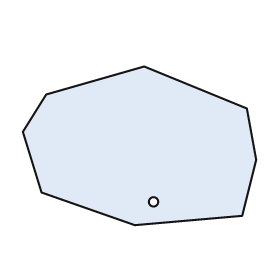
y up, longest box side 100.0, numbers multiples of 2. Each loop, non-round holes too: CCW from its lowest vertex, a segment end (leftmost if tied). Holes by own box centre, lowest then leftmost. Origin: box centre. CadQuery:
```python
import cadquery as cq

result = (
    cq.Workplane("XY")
    .moveTo(-2.0, -34.0)
    .lineTo(44.0, -30.0)
    .lineTo(50.0, -6.0)
    .lineTo(46.0, 16.0)
    .lineTo(2.0, 34.0)
    .lineTo(-40.0, 22.0)
    .lineTo(-50.0, 6.0)
    .lineTo(-42.0, -20.0)
    .close()
    .moveTo(6.0, -24.0)
    .circle(2.0)
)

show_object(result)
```